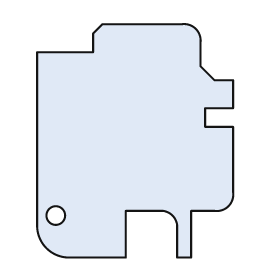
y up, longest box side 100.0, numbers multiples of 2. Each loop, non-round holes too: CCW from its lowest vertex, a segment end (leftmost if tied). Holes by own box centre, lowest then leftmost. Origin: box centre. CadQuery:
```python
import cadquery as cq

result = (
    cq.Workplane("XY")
    .moveTo(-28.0, -50.0)
    .lineTo(-4.0, -50.0)
    .lineTo(-4.0, -30.0)
    .lineTo(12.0, -30.0)
    .threePointArc((16.0, -32.0), (18.0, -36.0))
    .lineTo(18.0, -50.0)
    .lineTo(24.0, -50.0)
    .lineTo(24.0, -30.0)
    .lineTo(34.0, -30.0)
    .threePointArc((40.0, -28.0), (42.0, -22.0))
    .lineTo(42.0, 6.0)
    .lineTo(30.0, 6.0)
    .lineTo(30.0, 14.0)
    .lineTo(42.0, 14.0)
    .lineTo(42.0, 26.0)
    .lineTo(34.0, 26.0)
    .lineTo(28.0, 32.0)
    .lineTo(28.0, 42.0)
    .threePointArc((26.0, 48.0), (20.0, 50.0))
    .lineTo(-14.0, 50.0)
    .lineTo(-18.0, 46.0)
    .lineTo(-18.0, 38.0)
    .lineTo(-42.0, 38.0)
    .lineTo(-42.0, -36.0)
    .threePointArc((-38.0, -46.0), (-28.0, -50.0))
    .close()
    .moveTo(-34.0, -32.0)
    .circle(4.0)
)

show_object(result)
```